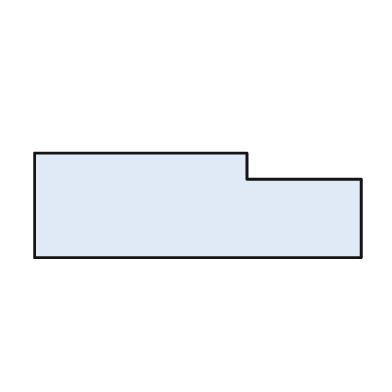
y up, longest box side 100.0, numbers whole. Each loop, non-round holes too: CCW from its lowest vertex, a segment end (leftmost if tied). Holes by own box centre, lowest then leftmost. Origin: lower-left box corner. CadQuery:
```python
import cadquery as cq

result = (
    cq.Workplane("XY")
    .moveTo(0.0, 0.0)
    .lineTo(100.0, 0.0)
    .lineTo(100.0, 24.0)
    .lineTo(65.0, 24.0)
    .lineTo(65.0, 32.0)
    .lineTo(0.0, 32.0)
    .close()
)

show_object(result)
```